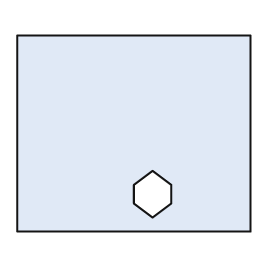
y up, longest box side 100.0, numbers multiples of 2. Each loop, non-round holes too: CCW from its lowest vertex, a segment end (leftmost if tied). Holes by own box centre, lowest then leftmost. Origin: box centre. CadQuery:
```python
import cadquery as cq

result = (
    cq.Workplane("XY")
    .moveTo(-50.0, -42.0)
    .lineTo(50.0, -42.0)
    .lineTo(50.0, 42.0)
    .lineTo(-50.0, 42.0)
    .close()
    .moveTo(8.0, -36.0)
    .lineTo(16.0, -30.0)
    .lineTo(16.0, -22.0)
    .lineTo(8.0, -16.0)
    .lineTo(0.0, -22.0)
    .lineTo(0.0, -30.0)
    .close()
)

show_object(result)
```